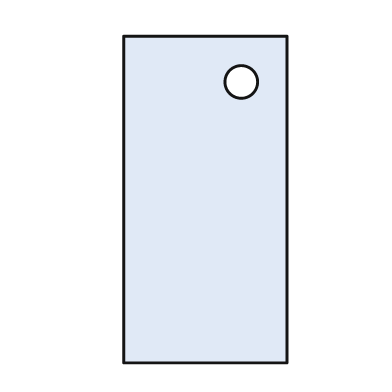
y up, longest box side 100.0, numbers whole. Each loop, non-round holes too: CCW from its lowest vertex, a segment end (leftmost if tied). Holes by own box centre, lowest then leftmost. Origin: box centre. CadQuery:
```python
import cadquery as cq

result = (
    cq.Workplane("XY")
    .moveTo(-25.0, -50.0)
    .lineTo(25.0, -50.0)
    .lineTo(25.0, 50.0)
    .lineTo(-25.0, 50.0)
    .close()
    .moveTo(11.0, 36.0)
    .circle(5.0)
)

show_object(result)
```